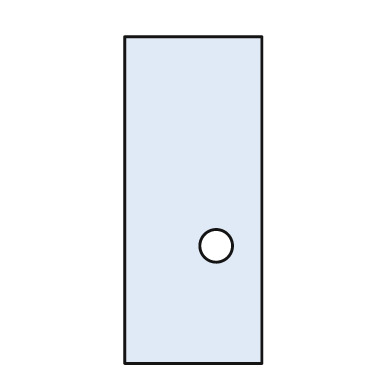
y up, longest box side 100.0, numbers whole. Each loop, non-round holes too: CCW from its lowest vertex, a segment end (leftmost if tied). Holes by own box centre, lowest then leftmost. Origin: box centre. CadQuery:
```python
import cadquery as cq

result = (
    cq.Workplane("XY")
    .moveTo(-21.0, -50.0)
    .lineTo(21.0, -50.0)
    .lineTo(21.0, 50.0)
    .lineTo(-21.0, 50.0)
    .close()
    .moveTo(7.0, -14.0)
    .circle(5.0)
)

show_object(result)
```